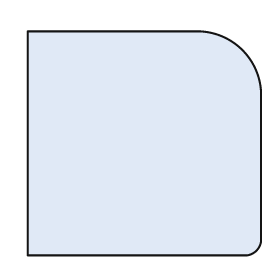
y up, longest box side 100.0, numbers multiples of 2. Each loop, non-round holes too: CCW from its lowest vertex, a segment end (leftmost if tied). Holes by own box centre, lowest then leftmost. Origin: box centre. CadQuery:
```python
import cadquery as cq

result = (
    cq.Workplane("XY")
    .moveTo(-50.0, -48.0)
    .lineTo(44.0, -48.0)
    .threePointArc((48.0, -46.0), (50.0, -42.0))
    .lineTo(50.0, 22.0)
    .threePointArc((42.0, 40.0), (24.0, 48.0))
    .lineTo(-50.0, 48.0)
    .close()
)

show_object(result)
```